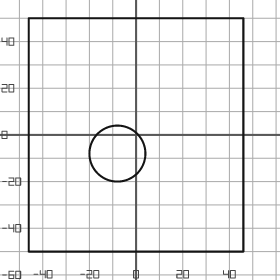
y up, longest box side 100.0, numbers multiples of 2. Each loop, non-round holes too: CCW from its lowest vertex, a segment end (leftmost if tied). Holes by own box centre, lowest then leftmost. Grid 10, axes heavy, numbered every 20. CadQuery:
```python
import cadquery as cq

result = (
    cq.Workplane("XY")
    .moveTo(-46.0, -50.0)
    .lineTo(46.0, -50.0)
    .lineTo(46.0, 50.0)
    .lineTo(-46.0, 50.0)
    .close()
    .moveTo(-8.0, -8.0)
    .circle(12.0)
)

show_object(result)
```